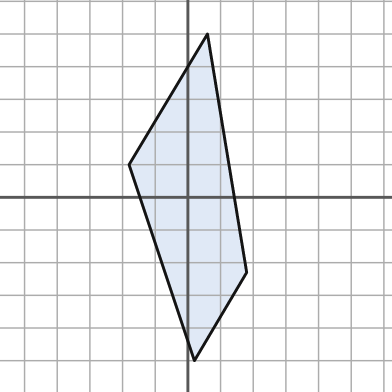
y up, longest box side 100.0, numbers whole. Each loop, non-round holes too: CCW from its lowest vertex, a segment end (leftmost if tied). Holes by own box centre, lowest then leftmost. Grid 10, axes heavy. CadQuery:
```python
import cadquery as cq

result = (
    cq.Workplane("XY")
    .moveTo(2.0, -50.0)
    .lineTo(18.0, -23.0)
    .lineTo(6.0, 50.0)
    .lineTo(-18.0, 10.0)
    .close()
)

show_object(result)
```